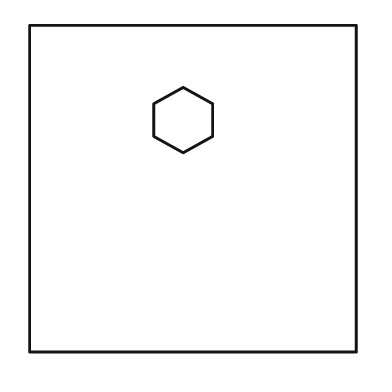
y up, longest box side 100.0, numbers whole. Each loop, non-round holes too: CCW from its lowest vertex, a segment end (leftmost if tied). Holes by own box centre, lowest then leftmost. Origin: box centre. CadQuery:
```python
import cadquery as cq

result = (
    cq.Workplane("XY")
    .moveTo(-50.0, -50.0)
    .lineTo(50.0, -50.0)
    .lineTo(50.0, 50.0)
    .lineTo(-50.0, 50.0)
    .close()
    .moveTo(-3.0, 11.0)
    .lineTo(6.0, 16.0)
    .lineTo(6.0, 26.0)
    .lineTo(-3.0, 31.0)
    .lineTo(-12.0, 26.0)
    .lineTo(-12.0, 16.0)
    .close()
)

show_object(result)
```